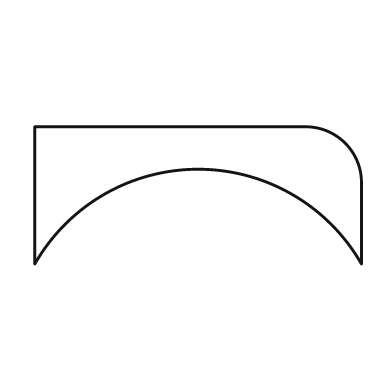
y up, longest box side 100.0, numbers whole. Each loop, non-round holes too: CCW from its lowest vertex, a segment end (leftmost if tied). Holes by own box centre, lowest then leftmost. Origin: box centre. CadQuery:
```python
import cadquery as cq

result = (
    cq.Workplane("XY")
    .moveTo(-50.0, -21.0)
    .threePointArc((0.0, 8.0), (50.0, -21.0))
    .lineTo(50.0, 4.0)
    .threePointArc((45.0, 16.0), (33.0, 21.0))
    .lineTo(-50.0, 21.0)
    .close()
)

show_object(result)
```